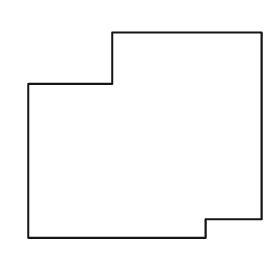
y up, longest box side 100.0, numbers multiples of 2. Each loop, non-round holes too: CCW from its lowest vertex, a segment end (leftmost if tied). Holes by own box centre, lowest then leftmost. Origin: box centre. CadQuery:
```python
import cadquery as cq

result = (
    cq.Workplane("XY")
    .moveTo(-50.0, -44.0)
    .lineTo(26.0, -44.0)
    .lineTo(26.0, -36.0)
    .lineTo(50.0, -36.0)
    .lineTo(50.0, 44.0)
    .lineTo(-14.0, 44.0)
    .lineTo(-14.0, 22.0)
    .lineTo(-50.0, 22.0)
    .close()
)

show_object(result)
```